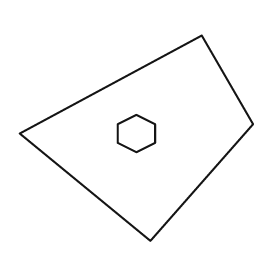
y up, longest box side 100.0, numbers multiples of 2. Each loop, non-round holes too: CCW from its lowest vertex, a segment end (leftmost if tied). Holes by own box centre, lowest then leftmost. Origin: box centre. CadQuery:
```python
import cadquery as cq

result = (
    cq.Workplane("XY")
    .moveTo(6.0, -44.0)
    .lineTo(50.0, 6.0)
    .lineTo(28.0, 44.0)
    .lineTo(-50.0, 2.0)
    .close()
    .moveTo(0.0, -6.0)
    .lineTo(8.0, -2.0)
    .lineTo(8.0, 6.0)
    .lineTo(0.0, 10.0)
    .lineTo(-8.0, 6.0)
    .lineTo(-8.0, -2.0)
    .close()
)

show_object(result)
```